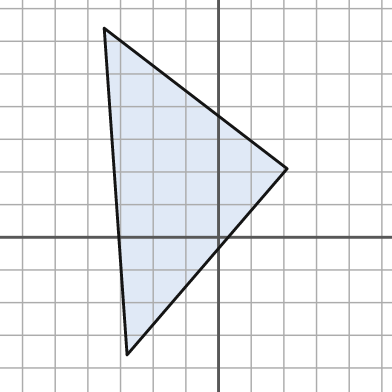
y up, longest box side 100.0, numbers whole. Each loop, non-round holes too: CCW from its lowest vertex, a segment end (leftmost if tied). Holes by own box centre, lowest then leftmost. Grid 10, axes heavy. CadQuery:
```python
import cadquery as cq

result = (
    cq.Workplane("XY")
    .moveTo(-28.0, -36.0)
    .lineTo(21.0, 21.0)
    .lineTo(-35.0, 64.0)
    .close()
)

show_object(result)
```